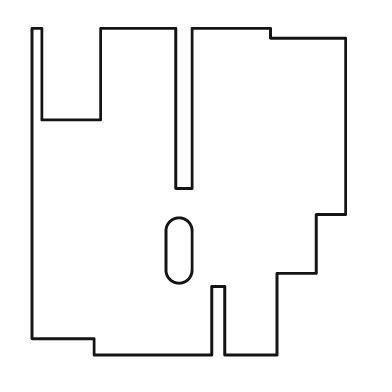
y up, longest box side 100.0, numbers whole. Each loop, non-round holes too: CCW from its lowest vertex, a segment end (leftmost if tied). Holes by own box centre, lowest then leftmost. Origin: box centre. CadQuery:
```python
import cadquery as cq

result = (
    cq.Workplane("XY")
    .moveTo(-29.0, -50.0)
    .lineTo(7.0, -50.0)
    .lineTo(7.0, -29.0)
    .lineTo(11.0, -29.0)
    .lineTo(11.0, -50.0)
    .lineTo(27.0, -50.0)
    .lineTo(27.0, -25.0)
    .lineTo(39.0, -25.0)
    .lineTo(39.0, -7.0)
    .lineTo(48.0, -7.0)
    .lineTo(48.0, 47.0)
    .lineTo(25.0, 47.0)
    .lineTo(25.0, 50.0)
    .lineTo(1.0, 50.0)
    .lineTo(1.0, 1.0)
    .lineTo(-4.0, 1.0)
    .lineTo(-4.0, 50.0)
    .lineTo(-27.0, 50.0)
    .lineTo(-27.0, 22.0)
    .lineTo(-45.0, 22.0)
    .lineTo(-45.0, 50.0)
    .lineTo(-48.0, 50.0)
    .lineTo(-48.0, -45.0)
    .lineTo(-29.0, -45.0)
    .close()
    .moveTo(-7.0, -24.0)
    .threePointArc((-3.0, -28.0), (1.0, -24.0))
    .lineTo(1.0, -12.0)
    .threePointArc((-3.0, -8.0), (-7.0, -12.0))
    .close()
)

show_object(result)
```